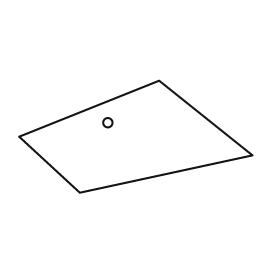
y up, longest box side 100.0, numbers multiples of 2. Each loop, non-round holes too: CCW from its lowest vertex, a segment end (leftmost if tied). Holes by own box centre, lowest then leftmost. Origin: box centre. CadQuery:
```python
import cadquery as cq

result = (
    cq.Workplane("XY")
    .moveTo(-24.0, -24.0)
    .lineTo(50.0, -8.0)
    .lineTo(10.0, 24.0)
    .lineTo(-50.0, 0.0)
    .close()
    .moveTo(-12.0, 6.0)
    .circle(2.0)
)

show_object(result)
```